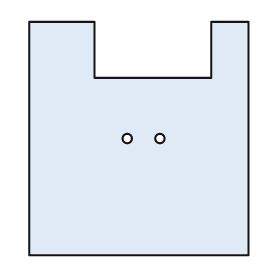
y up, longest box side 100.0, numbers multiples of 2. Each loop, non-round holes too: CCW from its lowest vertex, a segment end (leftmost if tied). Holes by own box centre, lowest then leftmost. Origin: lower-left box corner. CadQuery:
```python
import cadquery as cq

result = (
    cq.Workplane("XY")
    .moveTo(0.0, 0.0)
    .lineTo(94.0, 0.0)
    .lineTo(94.0, 100.0)
    .lineTo(78.0, 100.0)
    .lineTo(78.0, 76.0)
    .lineTo(28.0, 76.0)
    .lineTo(28.0, 100.0)
    .lineTo(0.0, 100.0)
    .close()
    .moveTo(42.0, 50.0)
    .circle(2.0)
    .moveTo(56.0, 50.0)
    .circle(2.0)
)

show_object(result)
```